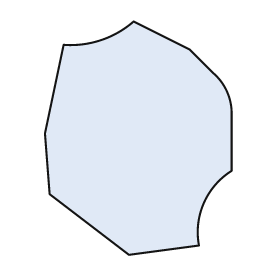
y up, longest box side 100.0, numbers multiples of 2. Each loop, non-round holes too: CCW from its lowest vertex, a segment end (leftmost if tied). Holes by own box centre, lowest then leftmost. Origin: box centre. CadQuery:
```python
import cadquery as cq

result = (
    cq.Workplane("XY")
    .moveTo(-4.0, -50.0)
    .lineTo(26.0, -46.0)
    .threePointArc((28.0, -28.0), (40.0, -14.0))
    .lineTo(40.0, 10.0)
    .threePointArc((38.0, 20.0), (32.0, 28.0))
    .lineTo(22.0, 38.0)
    .lineTo(-2.0, 50.0)
    .threePointArc((-16.0, 42.0), (-32.0, 40.0))
    .lineTo(-40.0, 2.0)
    .lineTo(-38.0, -24.0)
    .close()
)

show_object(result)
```